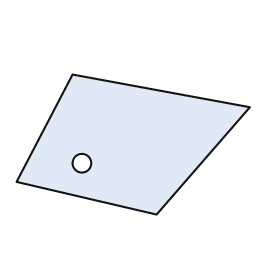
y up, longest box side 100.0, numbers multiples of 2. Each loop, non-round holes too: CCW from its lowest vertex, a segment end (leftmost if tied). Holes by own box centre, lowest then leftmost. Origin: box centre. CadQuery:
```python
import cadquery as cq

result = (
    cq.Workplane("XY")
    .moveTo(10.0, -30.0)
    .lineTo(50.0, 16.0)
    .lineTo(-26.0, 30.0)
    .lineTo(-50.0, -16.0)
    .close()
    .moveTo(-22.0, -8.0)
    .circle(4.0)
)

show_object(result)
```